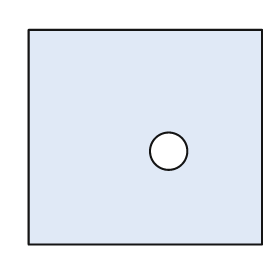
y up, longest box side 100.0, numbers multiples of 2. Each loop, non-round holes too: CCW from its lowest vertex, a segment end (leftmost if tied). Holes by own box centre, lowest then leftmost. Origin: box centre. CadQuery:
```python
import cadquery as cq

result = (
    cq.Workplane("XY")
    .moveTo(-50.0, -46.0)
    .lineTo(50.0, -46.0)
    .lineTo(50.0, 46.0)
    .lineTo(-50.0, 46.0)
    .close()
    .moveTo(10.0, -6.0)
    .circle(8.0)
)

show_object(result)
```